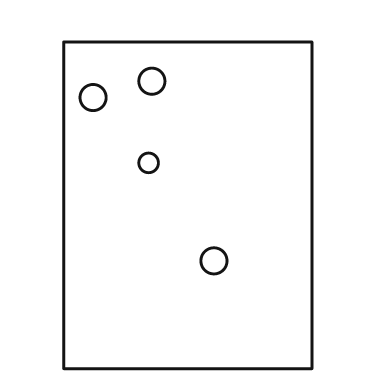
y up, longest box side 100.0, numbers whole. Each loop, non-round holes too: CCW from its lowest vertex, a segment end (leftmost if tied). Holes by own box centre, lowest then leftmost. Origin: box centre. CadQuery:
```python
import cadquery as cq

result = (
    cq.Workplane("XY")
    .moveTo(-38.0, -50.0)
    .lineTo(38.0, -50.0)
    .lineTo(38.0, 50.0)
    .lineTo(-38.0, 50.0)
    .close()
    .moveTo(8.0, -17.0)
    .circle(4.0)
    .moveTo(-12.0, 13.0)
    .circle(3.0)
    .moveTo(-29.0, 33.0)
    .circle(4.0)
    .moveTo(-11.0, 38.0)
    .circle(4.0)
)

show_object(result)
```